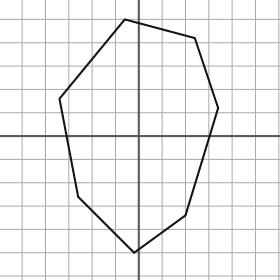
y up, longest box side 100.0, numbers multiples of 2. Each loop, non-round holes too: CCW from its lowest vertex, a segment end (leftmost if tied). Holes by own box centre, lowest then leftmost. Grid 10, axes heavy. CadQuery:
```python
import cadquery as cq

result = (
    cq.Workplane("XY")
    .moveTo(-2.0, -50.0)
    .lineTo(20.0, -34.0)
    .lineTo(34.0, 12.0)
    .lineTo(24.0, 42.0)
    .lineTo(-6.0, 50.0)
    .lineTo(-34.0, 16.0)
    .lineTo(-26.0, -26.0)
    .close()
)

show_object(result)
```